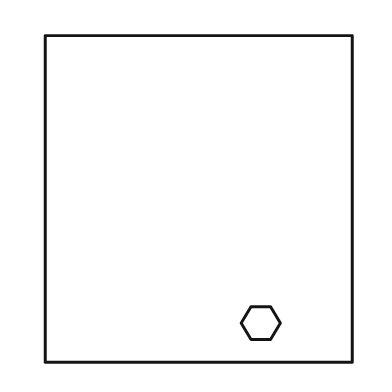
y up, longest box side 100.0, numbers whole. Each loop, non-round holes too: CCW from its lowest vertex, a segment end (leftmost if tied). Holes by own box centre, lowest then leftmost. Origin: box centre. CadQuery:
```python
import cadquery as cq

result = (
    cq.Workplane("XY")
    .moveTo(-47.0, -50.0)
    .lineTo(47.0, -50.0)
    .lineTo(47.0, 50.0)
    .lineTo(-47.0, 50.0)
    .close()
    .moveTo(16.0, -43.0)
    .lineTo(22.0, -43.0)
    .lineTo(25.0, -38.0)
    .lineTo(22.0, -33.0)
    .lineTo(16.0, -33.0)
    .lineTo(13.0, -38.0)
    .close()
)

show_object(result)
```